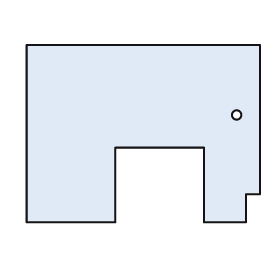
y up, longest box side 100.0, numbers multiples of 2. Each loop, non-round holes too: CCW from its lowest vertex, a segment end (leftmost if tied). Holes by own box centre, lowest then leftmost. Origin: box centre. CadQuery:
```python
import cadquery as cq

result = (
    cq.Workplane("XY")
    .moveTo(-50.0, -38.0)
    .lineTo(-12.0, -38.0)
    .lineTo(-12.0, -6.0)
    .lineTo(26.0, -6.0)
    .lineTo(26.0, -38.0)
    .lineTo(44.0, -38.0)
    .lineTo(44.0, -26.0)
    .lineTo(50.0, -26.0)
    .lineTo(50.0, 38.0)
    .lineTo(-50.0, 38.0)
    .close()
    .moveTo(40.0, 8.0)
    .circle(2.0)
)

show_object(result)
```